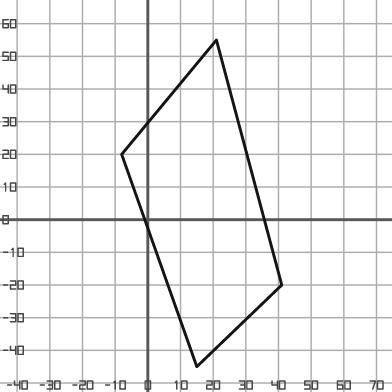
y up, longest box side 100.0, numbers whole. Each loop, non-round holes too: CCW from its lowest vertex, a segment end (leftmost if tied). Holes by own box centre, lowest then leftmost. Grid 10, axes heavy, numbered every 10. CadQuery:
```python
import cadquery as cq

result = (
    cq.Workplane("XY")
    .moveTo(15.0, -45.0)
    .lineTo(41.0, -20.0)
    .lineTo(21.0, 55.0)
    .lineTo(-8.0, 20.0)
    .close()
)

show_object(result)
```